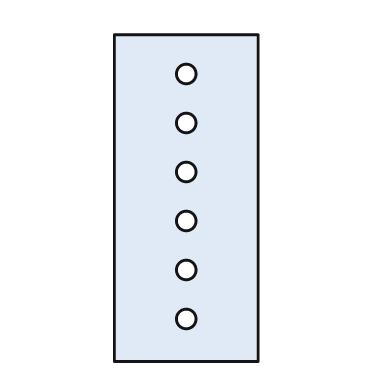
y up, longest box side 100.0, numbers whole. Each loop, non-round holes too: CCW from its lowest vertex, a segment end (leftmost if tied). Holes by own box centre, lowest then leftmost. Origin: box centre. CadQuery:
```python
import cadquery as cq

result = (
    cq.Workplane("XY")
    .moveTo(-22.0, -50.0)
    .lineTo(22.0, -50.0)
    .lineTo(22.0, 50.0)
    .lineTo(-22.0, 50.0)
    .close()
    .moveTo(0.0, -37.0)
    .circle(3.0)
    .moveTo(0.0, -22.0)
    .circle(3.0)
    .moveTo(0.0, -7.0)
    .circle(3.0)
    .moveTo(0.0, 8.0)
    .circle(3.0)
    .moveTo(0.0, 23.0)
    .circle(3.0)
    .moveTo(0.0, 38.0)
    .circle(3.0)
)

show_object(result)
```